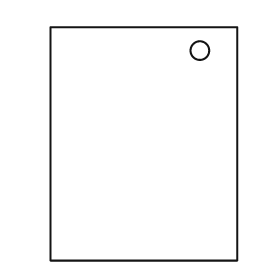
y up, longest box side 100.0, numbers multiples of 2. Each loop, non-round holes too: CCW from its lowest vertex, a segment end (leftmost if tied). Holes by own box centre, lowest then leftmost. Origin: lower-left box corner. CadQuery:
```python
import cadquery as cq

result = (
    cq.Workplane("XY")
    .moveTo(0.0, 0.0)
    .lineTo(80.0, 0.0)
    .lineTo(80.0, 100.0)
    .lineTo(0.0, 100.0)
    .close()
    .moveTo(64.0, 90.0)
    .circle(4.0)
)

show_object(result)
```